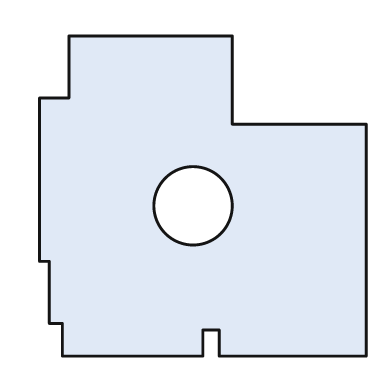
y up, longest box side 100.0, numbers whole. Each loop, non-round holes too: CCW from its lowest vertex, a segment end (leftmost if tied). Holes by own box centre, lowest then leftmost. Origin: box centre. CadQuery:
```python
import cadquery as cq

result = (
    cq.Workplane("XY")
    .moveTo(-43.0, -49.0)
    .lineTo(0.0, -49.0)
    .lineTo(0.0, -41.0)
    .lineTo(5.0, -41.0)
    .lineTo(5.0, -49.0)
    .lineTo(50.0, -49.0)
    .lineTo(50.0, 22.0)
    .lineTo(9.0, 22.0)
    .lineTo(9.0, 49.0)
    .lineTo(-41.0, 49.0)
    .lineTo(-41.0, 30.0)
    .lineTo(-50.0, 30.0)
    .lineTo(-50.0, -20.0)
    .lineTo(-47.0, -20.0)
    .lineTo(-47.0, -39.0)
    .lineTo(-43.0, -39.0)
    .close()
    .moveTo(-3.0, -3.0)
    .circle(12.0)
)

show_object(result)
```